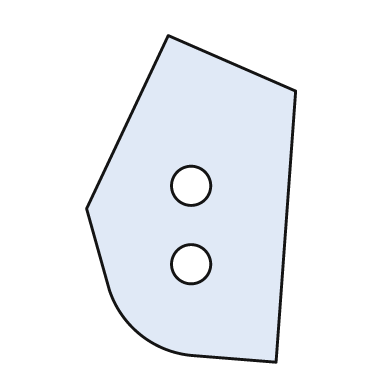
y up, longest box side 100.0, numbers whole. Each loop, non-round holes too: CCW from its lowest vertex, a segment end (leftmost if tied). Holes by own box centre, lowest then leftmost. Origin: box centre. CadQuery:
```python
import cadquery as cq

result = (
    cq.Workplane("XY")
    .moveTo(26.0, -50.0)
    .lineTo(32.0, 33.0)
    .lineTo(-7.0, 50.0)
    .lineTo(-32.0, -3.0)
    .lineTo(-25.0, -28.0)
    .threePointArc((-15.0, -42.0), (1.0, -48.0))
    .close()
    .moveTo(0.0, -20.0)
    .circle(6.0)
    .moveTo(0.0, 4.0)
    .circle(6.0)
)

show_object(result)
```